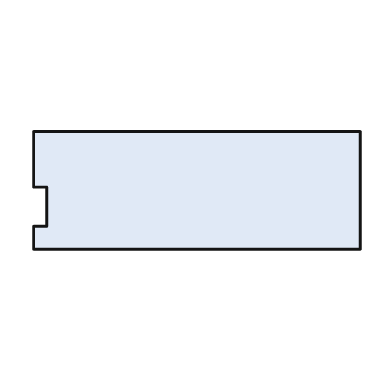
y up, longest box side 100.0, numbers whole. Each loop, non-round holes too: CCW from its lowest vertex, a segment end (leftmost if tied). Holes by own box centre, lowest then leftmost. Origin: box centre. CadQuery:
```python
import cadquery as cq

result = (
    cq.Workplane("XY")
    .moveTo(-50.0, -18.0)
    .lineTo(50.0, -18.0)
    .lineTo(50.0, 18.0)
    .lineTo(-50.0, 18.0)
    .lineTo(-50.0, 1.0)
    .lineTo(-46.0, 1.0)
    .lineTo(-46.0, -11.0)
    .lineTo(-50.0, -11.0)
    .close()
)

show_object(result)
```